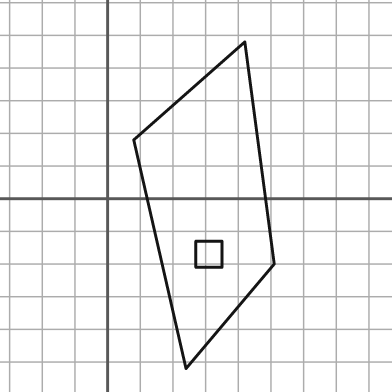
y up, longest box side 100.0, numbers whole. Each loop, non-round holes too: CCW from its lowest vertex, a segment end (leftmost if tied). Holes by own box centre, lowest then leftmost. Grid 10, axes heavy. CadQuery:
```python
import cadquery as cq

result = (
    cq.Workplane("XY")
    .moveTo(24.0, -52.0)
    .lineTo(51.0, -20.0)
    .lineTo(42.0, 48.0)
    .lineTo(8.0, 18.0)
    .close()
    .moveTo(27.0, -21.0)
    .lineTo(35.0, -21.0)
    .lineTo(35.0, -13.0)
    .lineTo(27.0, -13.0)
    .close()
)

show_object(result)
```